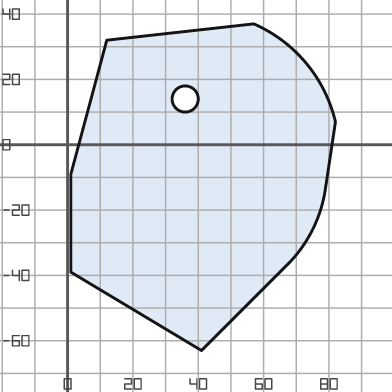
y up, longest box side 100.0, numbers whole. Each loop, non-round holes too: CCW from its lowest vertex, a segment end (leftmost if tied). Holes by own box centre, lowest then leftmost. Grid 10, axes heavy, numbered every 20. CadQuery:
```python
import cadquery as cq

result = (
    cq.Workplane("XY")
    .moveTo(41.0, -63.0)
    .lineTo(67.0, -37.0)
    .threePointArc((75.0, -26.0), (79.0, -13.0))
    .lineTo(82.0, 7.0)
    .threePointArc((73.0, 25.0), (57.0, 37.0))
    .lineTo(12.0, 32.0)
    .lineTo(1.0, -9.0)
    .lineTo(1.0, -39.0)
    .close()
    .moveTo(36.0, 14.0)
    .circle(4.0)
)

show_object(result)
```